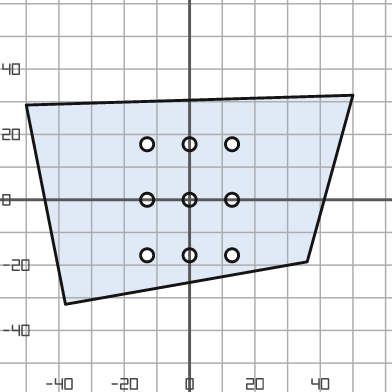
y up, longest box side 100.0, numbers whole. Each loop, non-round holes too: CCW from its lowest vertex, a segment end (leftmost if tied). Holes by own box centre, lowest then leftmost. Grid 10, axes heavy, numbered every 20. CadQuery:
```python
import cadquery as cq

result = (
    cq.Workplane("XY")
    .moveTo(-38.0, -32.0)
    .lineTo(36.0, -19.0)
    .lineTo(50.0, 32.0)
    .lineTo(-50.0, 29.0)
    .close()
    .moveTo(-13.0, -17.0)
    .circle(2.0)
    .moveTo(0.0, -17.0)
    .circle(2.0)
    .moveTo(13.0, -17.0)
    .circle(2.0)
    .moveTo(-13.0, 0.0)
    .circle(2.0)
    .moveTo(0.0, 0.0)
    .circle(2.0)
    .moveTo(13.0, 0.0)
    .circle(2.0)
    .moveTo(-13.0, 17.0)
    .circle(2.0)
    .moveTo(0.0, 17.0)
    .circle(2.0)
    .moveTo(13.0, 17.0)
    .circle(2.0)
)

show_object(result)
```